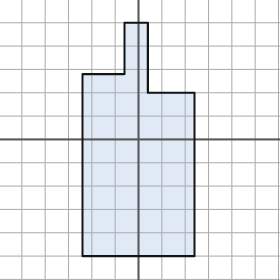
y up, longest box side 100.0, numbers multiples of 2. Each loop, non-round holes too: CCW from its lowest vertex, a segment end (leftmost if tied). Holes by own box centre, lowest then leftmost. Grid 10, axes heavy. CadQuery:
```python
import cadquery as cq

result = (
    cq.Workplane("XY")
    .moveTo(-24.0, -50.0)
    .lineTo(24.0, -50.0)
    .lineTo(24.0, 20.0)
    .lineTo(4.0, 20.0)
    .lineTo(4.0, 50.0)
    .lineTo(-6.0, 50.0)
    .lineTo(-6.0, 28.0)
    .lineTo(-24.0, 28.0)
    .close()
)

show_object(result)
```